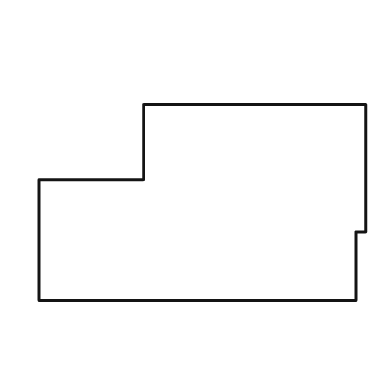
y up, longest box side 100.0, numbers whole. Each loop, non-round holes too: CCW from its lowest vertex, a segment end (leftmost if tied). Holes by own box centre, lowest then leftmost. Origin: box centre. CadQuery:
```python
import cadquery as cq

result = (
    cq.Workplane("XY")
    .moveTo(-50.0, -30.0)
    .lineTo(47.0, -30.0)
    .lineTo(47.0, -9.0)
    .lineTo(50.0, -9.0)
    .lineTo(50.0, 30.0)
    .lineTo(-18.0, 30.0)
    .lineTo(-18.0, 7.0)
    .lineTo(-50.0, 7.0)
    .close()
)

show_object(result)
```